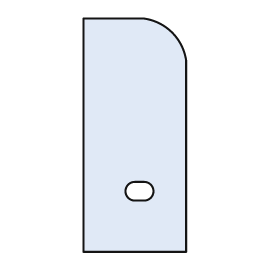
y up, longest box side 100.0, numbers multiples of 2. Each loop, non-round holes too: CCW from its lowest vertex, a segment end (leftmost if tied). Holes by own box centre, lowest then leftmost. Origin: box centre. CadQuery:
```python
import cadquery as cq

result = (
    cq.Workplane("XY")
    .moveTo(-22.0, -50.0)
    .lineTo(22.0, -50.0)
    .lineTo(22.0, 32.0)
    .threePointArc((16.0, 44.0), (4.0, 50.0))
    .lineTo(-22.0, 50.0)
    .close()
    .moveTo(0.0, -28.0)
    .lineTo(4.0, -28.0)
    .threePointArc((8.0, -24.0), (4.0, -20.0))
    .lineTo(0.0, -20.0)
    .threePointArc((-4.0, -24.0), (0.0, -28.0))
    .close()
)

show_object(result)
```